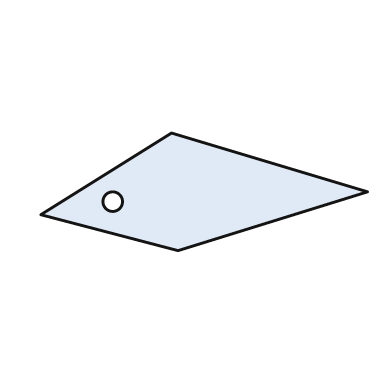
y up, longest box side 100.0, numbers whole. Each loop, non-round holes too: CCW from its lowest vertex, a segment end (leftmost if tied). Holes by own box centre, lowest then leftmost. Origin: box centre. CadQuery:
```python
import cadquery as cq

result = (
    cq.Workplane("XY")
    .moveTo(-8.0, -18.0)
    .lineTo(50.0, 0.0)
    .lineTo(-10.0, 18.0)
    .lineTo(-50.0, -7.0)
    .close()
    .moveTo(-28.0, -3.0)
    .circle(3.0)
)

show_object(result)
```